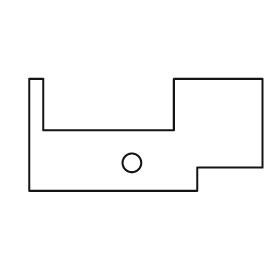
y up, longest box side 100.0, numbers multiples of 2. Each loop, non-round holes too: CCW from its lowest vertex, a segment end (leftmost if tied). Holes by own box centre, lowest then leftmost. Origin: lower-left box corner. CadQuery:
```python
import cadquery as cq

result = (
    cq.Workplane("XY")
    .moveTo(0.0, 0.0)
    .lineTo(72.0, 0.0)
    .lineTo(72.0, 10.0)
    .lineTo(100.0, 10.0)
    .lineTo(100.0, 48.0)
    .lineTo(62.0, 48.0)
    .lineTo(62.0, 26.0)
    .lineTo(6.0, 26.0)
    .lineTo(6.0, 48.0)
    .lineTo(0.0, 48.0)
    .close()
    .moveTo(44.0, 12.0)
    .circle(4.0)
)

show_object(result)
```